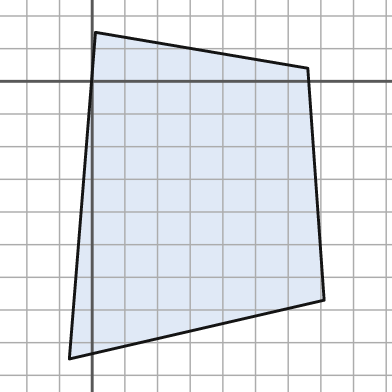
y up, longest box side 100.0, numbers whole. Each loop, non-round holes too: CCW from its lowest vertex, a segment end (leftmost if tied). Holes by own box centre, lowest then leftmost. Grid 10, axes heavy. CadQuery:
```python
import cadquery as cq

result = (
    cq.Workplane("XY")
    .moveTo(-7.0, -85.0)
    .lineTo(71.0, -67.0)
    .lineTo(66.0, 4.0)
    .lineTo(1.0, 15.0)
    .close()
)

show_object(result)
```